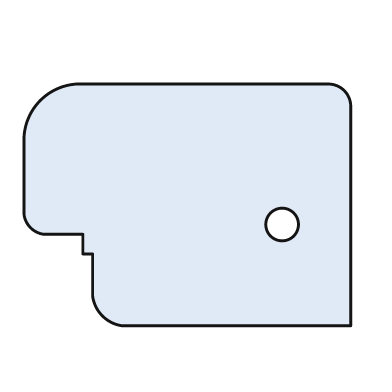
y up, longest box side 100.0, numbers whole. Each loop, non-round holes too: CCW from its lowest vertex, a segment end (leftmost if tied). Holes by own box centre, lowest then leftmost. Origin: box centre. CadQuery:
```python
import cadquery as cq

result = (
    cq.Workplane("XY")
    .moveTo(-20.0, -37.0)
    .lineTo(50.0, -37.0)
    .lineTo(50.0, 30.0)
    .threePointArc((48.0, 35.0), (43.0, 37.0))
    .lineTo(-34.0, 37.0)
    .threePointArc((-45.0, 32.0), (-50.0, 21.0))
    .lineTo(-50.0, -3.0)
    .threePointArc((-48.0, -7.0), (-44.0, -9.0))
    .lineTo(-32.0, -9.0)
    .lineTo(-32.0, -15.0)
    .lineTo(-29.0, -15.0)
    .lineTo(-29.0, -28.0)
    .threePointArc((-26.0, -34.0), (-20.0, -37.0))
    .close()
    .moveTo(29.0, -6.0)
    .circle(5.0)
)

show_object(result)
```